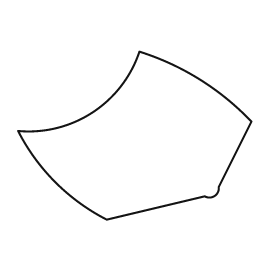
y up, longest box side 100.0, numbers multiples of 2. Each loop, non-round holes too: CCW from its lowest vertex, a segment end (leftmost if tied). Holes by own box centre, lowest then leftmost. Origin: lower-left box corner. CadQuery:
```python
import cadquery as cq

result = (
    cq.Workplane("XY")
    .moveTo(38.0, 0.0)
    .lineTo(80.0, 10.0)
    .threePointArc((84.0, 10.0), (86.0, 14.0))
    .lineTo(100.0, 42.0)
    .threePointArc((78.0, 60.0), (52.0, 72.0))
    .threePointArc((32.0, 46.0), (0.0, 38.0))
    .threePointArc((16.0, 16.0), (38.0, 0.0))
    .close()
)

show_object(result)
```